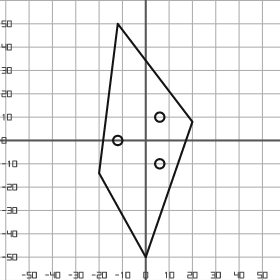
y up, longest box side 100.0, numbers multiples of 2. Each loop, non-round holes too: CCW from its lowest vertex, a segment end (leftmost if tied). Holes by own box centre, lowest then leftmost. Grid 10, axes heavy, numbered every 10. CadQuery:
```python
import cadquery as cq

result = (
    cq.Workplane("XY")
    .moveTo(0.0, -50.0)
    .lineTo(20.0, 8.0)
    .lineTo(-12.0, 50.0)
    .lineTo(-20.0, -14.0)
    .close()
    .moveTo(6.0, -10.0)
    .circle(2.0)
    .moveTo(-12.0, 0.0)
    .circle(2.0)
    .moveTo(6.0, 10.0)
    .circle(2.0)
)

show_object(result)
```